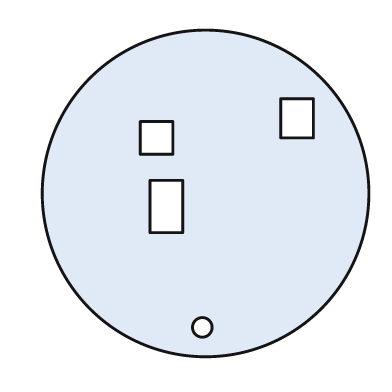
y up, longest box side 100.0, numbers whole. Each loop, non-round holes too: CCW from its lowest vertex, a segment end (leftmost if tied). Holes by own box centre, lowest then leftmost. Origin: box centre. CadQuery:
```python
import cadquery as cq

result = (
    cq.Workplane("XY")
    .moveTo(0.0, 0.0)
    .circle(50.0)
    .moveTo(-1.0, -41.0)
    .circle(3.0)
    .moveTo(-17.0, -12.0)
    .lineTo(-7.0, -12.0)
    .lineTo(-7.0, 4.0)
    .lineTo(-17.0, 4.0)
    .close()
    .moveTo(-20.0, 12.0)
    .lineTo(-10.0, 12.0)
    .lineTo(-10.0, 22.0)
    .lineTo(-20.0, 22.0)
    .close()
    .moveTo(23.0, 17.0)
    .lineTo(33.0, 17.0)
    .lineTo(33.0, 29.0)
    .lineTo(23.0, 29.0)
    .close()
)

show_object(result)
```